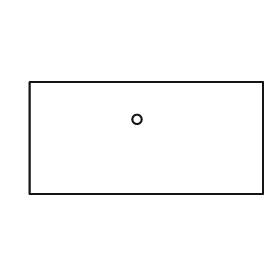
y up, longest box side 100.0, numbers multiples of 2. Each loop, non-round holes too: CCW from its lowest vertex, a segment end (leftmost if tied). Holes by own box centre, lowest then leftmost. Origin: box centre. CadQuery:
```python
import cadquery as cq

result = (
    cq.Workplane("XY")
    .moveTo(-50.0, -24.0)
    .lineTo(50.0, -24.0)
    .lineTo(50.0, 24.0)
    .lineTo(-50.0, 24.0)
    .close()
    .moveTo(-4.0, 8.0)
    .circle(2.0)
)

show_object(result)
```